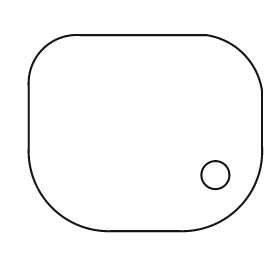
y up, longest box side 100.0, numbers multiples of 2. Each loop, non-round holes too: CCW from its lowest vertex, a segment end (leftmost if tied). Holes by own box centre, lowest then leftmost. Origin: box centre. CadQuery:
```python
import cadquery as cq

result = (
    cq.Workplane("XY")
    .moveTo(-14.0, -42.0)
    .lineTo(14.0, -42.0)
    .threePointArc((40.0, -32.0), (50.0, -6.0))
    .lineTo(50.0, 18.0)
    .threePointArc((42.0, 34.0), (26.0, 42.0))
    .lineTo(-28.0, 42.0)
    .threePointArc((-44.0, 36.0), (-50.0, 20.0))
    .lineTo(-50.0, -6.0)
    .threePointArc((-40.0, -32.0), (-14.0, -42.0))
    .close()
    .moveTo(30.0, -18.0)
    .circle(6.0)
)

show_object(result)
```